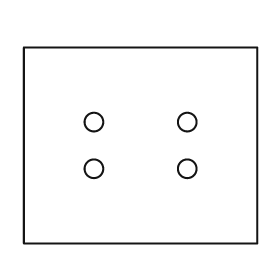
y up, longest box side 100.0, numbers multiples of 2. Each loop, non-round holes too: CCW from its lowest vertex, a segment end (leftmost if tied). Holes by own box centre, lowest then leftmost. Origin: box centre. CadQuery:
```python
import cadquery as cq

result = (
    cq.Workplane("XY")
    .moveTo(-50.0, -42.0)
    .lineTo(50.0, -42.0)
    .lineTo(50.0, 42.0)
    .lineTo(-50.0, 42.0)
    .close()
    .moveTo(-20.0, -10.0)
    .circle(4.0)
    .moveTo(20.0, -10.0)
    .circle(4.0)
    .moveTo(-20.0, 10.0)
    .circle(4.0)
    .moveTo(20.0, 10.0)
    .circle(4.0)
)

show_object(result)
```